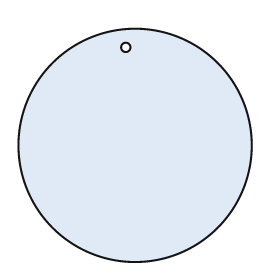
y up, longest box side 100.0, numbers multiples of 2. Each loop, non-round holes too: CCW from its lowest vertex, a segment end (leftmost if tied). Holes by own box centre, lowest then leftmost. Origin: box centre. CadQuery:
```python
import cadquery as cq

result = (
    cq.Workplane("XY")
    .moveTo(0.0, 0.0)
    .circle(50.0)
    .moveTo(-4.0, 42.0)
    .circle(2.0)
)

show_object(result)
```